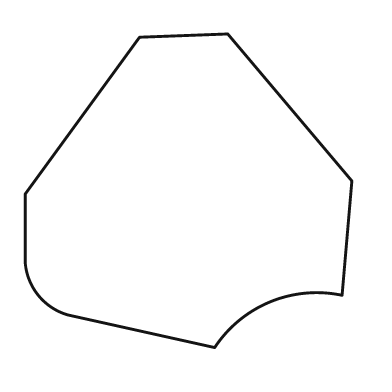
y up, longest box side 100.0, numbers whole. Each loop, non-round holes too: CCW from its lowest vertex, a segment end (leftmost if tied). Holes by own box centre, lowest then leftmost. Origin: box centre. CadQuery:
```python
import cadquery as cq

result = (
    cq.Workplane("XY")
    .moveTo(8.0, -48.0)
    .threePointArc((25.0, -34.0), (47.0, -32.0))
    .lineTo(50.0, 3.0)
    .lineTo(12.0, 48.0)
    .lineTo(-15.0, 47.0)
    .lineTo(-50.0, -1.0)
    .lineTo(-50.0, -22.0)
    .threePointArc((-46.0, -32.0), (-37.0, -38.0))
    .close()
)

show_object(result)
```